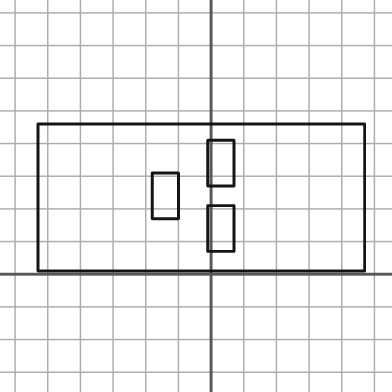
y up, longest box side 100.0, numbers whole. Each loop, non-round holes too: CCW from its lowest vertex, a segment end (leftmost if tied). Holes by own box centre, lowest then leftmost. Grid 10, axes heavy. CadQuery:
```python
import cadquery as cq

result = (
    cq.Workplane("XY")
    .moveTo(-53.0, 1.0)
    .lineTo(47.0, 1.0)
    .lineTo(47.0, 46.0)
    .lineTo(-53.0, 46.0)
    .close()
    .moveTo(-1.0, 7.0)
    .lineTo(7.0, 7.0)
    .lineTo(7.0, 21.0)
    .lineTo(-1.0, 21.0)
    .close()
    .moveTo(-18.0, 17.0)
    .lineTo(-10.0, 17.0)
    .lineTo(-10.0, 31.0)
    .lineTo(-18.0, 31.0)
    .close()
    .moveTo(-1.0, 27.0)
    .lineTo(7.0, 27.0)
    .lineTo(7.0, 41.0)
    .lineTo(-1.0, 41.0)
    .close()
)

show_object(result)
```